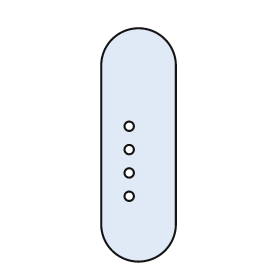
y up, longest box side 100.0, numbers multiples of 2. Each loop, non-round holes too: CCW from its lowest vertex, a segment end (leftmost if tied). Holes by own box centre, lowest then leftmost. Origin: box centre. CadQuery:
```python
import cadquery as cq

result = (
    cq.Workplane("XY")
    .moveTo(-16.0, -34.0)
    .threePointArc((0.0, -50.0), (16.0, -34.0))
    .lineTo(16.0, 34.0)
    .threePointArc((0.0, 50.0), (-16.0, 34.0))
    .close()
    .moveTo(-4.0, -22.0)
    .circle(2.0)
    .moveTo(-4.0, -12.0)
    .circle(2.0)
    .moveTo(-4.0, -2.0)
    .circle(2.0)
    .moveTo(-4.0, 8.0)
    .circle(2.0)
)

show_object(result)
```